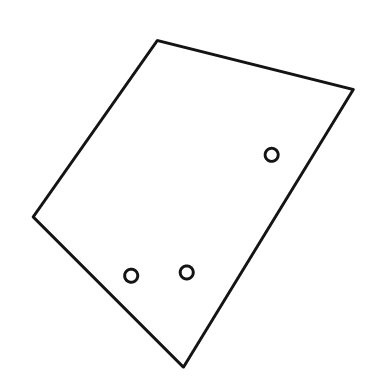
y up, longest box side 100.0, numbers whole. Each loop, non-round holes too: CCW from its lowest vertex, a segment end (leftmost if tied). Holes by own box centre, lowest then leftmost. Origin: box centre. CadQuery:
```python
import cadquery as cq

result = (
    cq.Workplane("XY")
    .moveTo(-3.0, -50.0)
    .lineTo(49.0, 35.0)
    .lineTo(-11.0, 50.0)
    .lineTo(-49.0, -4.0)
    .close()
    .moveTo(-19.0, -22.0)
    .circle(2.0)
    .moveTo(-2.0, -21.0)
    .circle(2.0)
    .moveTo(24.0, 15.0)
    .circle(2.0)
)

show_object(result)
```